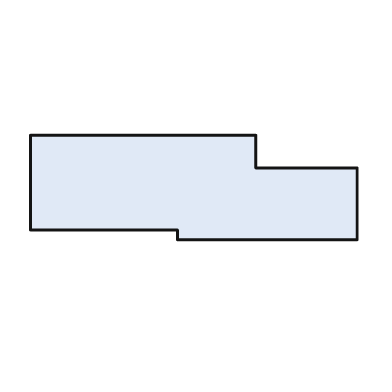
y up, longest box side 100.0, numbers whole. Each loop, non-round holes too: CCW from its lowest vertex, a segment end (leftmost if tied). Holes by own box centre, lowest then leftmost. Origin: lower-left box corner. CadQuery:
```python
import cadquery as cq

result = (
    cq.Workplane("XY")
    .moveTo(45.0, 0.0)
    .lineTo(100.0, 0.0)
    .lineTo(100.0, 22.0)
    .lineTo(69.0, 22.0)
    .lineTo(69.0, 32.0)
    .lineTo(0.0, 32.0)
    .lineTo(0.0, 3.0)
    .lineTo(45.0, 3.0)
    .close()
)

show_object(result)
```